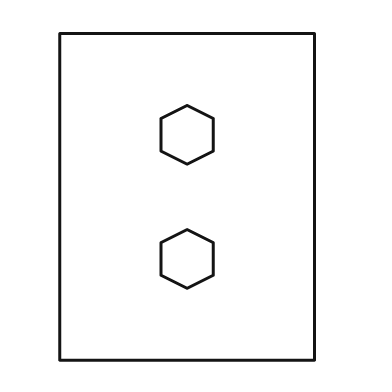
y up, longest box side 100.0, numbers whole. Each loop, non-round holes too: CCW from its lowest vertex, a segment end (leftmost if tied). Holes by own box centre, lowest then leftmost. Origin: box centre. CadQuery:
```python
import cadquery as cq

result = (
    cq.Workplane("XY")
    .moveTo(-39.0, -50.0)
    .lineTo(39.0, -50.0)
    .lineTo(39.0, 50.0)
    .lineTo(-39.0, 50.0)
    .close()
    .moveTo(0.0, -28.0)
    .lineTo(8.0, -24.0)
    .lineTo(8.0, -14.0)
    .lineTo(0.0, -10.0)
    .lineTo(-8.0, -14.0)
    .lineTo(-8.0, -24.0)
    .close()
    .moveTo(0.0, 10.0)
    .lineTo(8.0, 14.0)
    .lineTo(8.0, 24.0)
    .lineTo(0.0, 28.0)
    .lineTo(-8.0, 24.0)
    .lineTo(-8.0, 14.0)
    .close()
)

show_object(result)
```